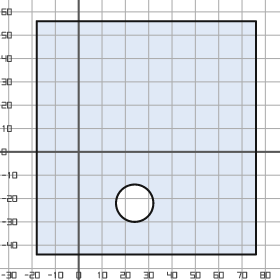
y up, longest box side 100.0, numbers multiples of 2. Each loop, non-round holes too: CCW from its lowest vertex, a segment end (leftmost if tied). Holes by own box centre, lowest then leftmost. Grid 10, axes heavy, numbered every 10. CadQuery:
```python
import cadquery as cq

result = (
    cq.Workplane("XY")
    .moveTo(-18.0, -44.0)
    .lineTo(76.0, -44.0)
    .lineTo(76.0, 56.0)
    .lineTo(-18.0, 56.0)
    .close()
    .moveTo(24.0, -22.0)
    .circle(8.0)
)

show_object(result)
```